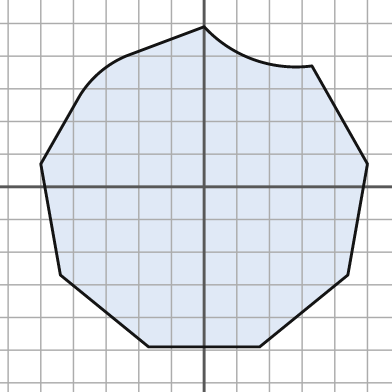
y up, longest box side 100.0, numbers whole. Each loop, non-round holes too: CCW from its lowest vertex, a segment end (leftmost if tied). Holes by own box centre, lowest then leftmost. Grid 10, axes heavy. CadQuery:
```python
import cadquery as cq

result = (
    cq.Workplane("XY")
    .moveTo(-17.0, -49.0)
    .lineTo(17.0, -49.0)
    .lineTo(44.0, -27.0)
    .lineTo(50.0, 7.0)
    .lineTo(33.0, 37.0)
    .threePointArc((15.0, 39.0), (0.0, 49.0))
    .lineTo(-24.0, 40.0)
    .threePointArc((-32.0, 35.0), (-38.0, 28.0))
    .lineTo(-50.0, 7.0)
    .lineTo(-44.0, -27.0)
    .close()
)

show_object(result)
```